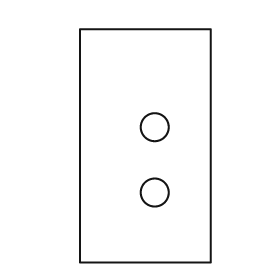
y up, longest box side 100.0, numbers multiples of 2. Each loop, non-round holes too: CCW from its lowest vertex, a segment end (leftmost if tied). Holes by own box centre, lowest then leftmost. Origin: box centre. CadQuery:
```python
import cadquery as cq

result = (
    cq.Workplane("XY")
    .moveTo(-28.0, -50.0)
    .lineTo(28.0, -50.0)
    .lineTo(28.0, 50.0)
    .lineTo(-28.0, 50.0)
    .close()
    .moveTo(4.0, -20.0)
    .circle(6.0)
    .moveTo(4.0, 8.0)
    .circle(6.0)
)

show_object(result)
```